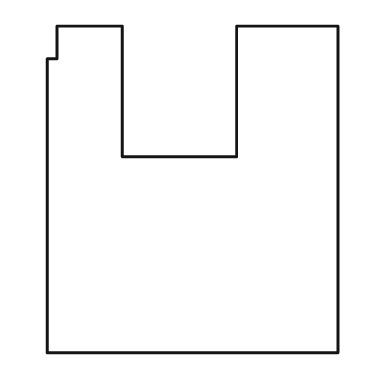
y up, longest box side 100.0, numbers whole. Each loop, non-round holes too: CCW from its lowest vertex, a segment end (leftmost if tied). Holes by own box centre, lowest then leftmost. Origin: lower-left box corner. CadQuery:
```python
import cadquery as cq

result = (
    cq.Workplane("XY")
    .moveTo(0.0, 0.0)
    .lineTo(89.0, 0.0)
    .lineTo(89.0, 100.0)
    .lineTo(58.0, 100.0)
    .lineTo(58.0, 60.0)
    .lineTo(23.0, 60.0)
    .lineTo(23.0, 100.0)
    .lineTo(3.0, 100.0)
    .lineTo(3.0, 90.0)
    .lineTo(0.0, 90.0)
    .close()
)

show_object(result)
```